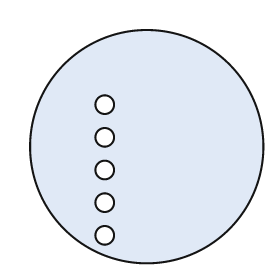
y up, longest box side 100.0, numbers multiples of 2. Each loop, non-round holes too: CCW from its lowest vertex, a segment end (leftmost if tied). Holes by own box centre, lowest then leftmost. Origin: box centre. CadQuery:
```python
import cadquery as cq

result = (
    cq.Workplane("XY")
    .moveTo(0.0, 0.0)
    .circle(50.0)
    .moveTo(-18.0, -38.0)
    .circle(4.0)
    .moveTo(-18.0, -24.0)
    .circle(4.0)
    .moveTo(-18.0, -10.0)
    .circle(4.0)
    .moveTo(-18.0, 4.0)
    .circle(4.0)
    .moveTo(-18.0, 18.0)
    .circle(4.0)
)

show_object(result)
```